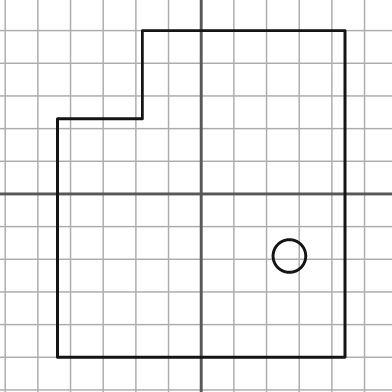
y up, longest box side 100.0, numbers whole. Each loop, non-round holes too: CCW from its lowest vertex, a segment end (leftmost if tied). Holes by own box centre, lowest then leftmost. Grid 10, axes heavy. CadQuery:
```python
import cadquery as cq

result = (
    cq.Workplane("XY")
    .moveTo(-44.0, -50.0)
    .lineTo(44.0, -50.0)
    .lineTo(44.0, 50.0)
    .lineTo(-18.0, 50.0)
    .lineTo(-18.0, 23.0)
    .lineTo(-44.0, 23.0)
    .close()
    .moveTo(27.0, -19.0)
    .circle(5.0)
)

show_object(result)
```